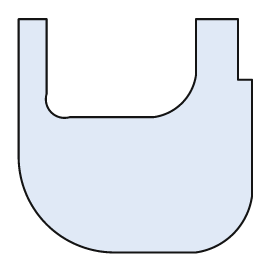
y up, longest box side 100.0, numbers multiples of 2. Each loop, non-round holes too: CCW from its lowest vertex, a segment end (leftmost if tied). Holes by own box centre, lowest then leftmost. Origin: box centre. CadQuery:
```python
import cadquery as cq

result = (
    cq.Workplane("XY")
    .moveTo(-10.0, -50.0)
    .lineTo(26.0, -50.0)
    .threePointArc((42.0, -42.0), (50.0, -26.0))
    .lineTo(50.0, 24.0)
    .lineTo(44.0, 24.0)
    .lineTo(44.0, 50.0)
    .lineTo(26.0, 50.0)
    .lineTo(26.0, 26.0)
    .threePointArc((20.0, 14.0), (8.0, 8.0))
    .lineTo(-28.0, 8.0)
    .threePointArc((-36.0, 10.0), (-38.0, 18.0))
    .lineTo(-38.0, 50.0)
    .lineTo(-50.0, 50.0)
    .lineTo(-50.0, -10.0)
    .threePointArc((-38.0, -38.0), (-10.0, -50.0))
    .close()
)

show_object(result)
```